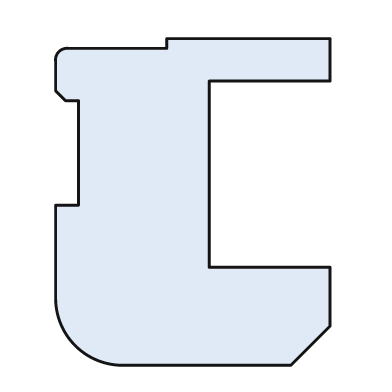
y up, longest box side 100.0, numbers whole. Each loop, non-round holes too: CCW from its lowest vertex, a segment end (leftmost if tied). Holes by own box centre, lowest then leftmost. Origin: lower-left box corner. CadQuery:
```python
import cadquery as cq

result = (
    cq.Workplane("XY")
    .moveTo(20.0, 0.0)
    .lineTo(72.0, 0.0)
    .lineTo(84.0, 12.0)
    .lineTo(84.0, 30.0)
    .lineTo(47.0, 30.0)
    .lineTo(47.0, 87.0)
    .lineTo(84.0, 87.0)
    .lineTo(84.0, 100.0)
    .lineTo(34.0, 100.0)
    .lineTo(34.0, 97.0)
    .lineTo(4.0, 97.0)
    .threePointArc((1.0, 96.0), (0.0, 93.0))
    .lineTo(0.0, 84.0)
    .lineTo(3.0, 81.0)
    .lineTo(7.0, 81.0)
    .lineTo(7.0, 49.0)
    .lineTo(0.0, 49.0)
    .lineTo(0.0, 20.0)
    .threePointArc((6.0, 6.0), (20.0, 0.0))
    .close()
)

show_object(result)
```